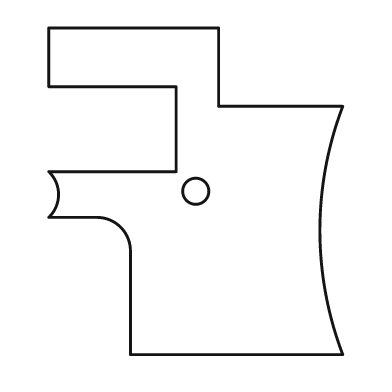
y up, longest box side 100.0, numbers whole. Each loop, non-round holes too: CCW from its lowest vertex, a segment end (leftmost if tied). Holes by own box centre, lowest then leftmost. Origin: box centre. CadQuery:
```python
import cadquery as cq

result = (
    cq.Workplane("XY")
    .moveTo(-20.0, -50.0)
    .lineTo(45.0, -50.0)
    .threePointArc((38.0, -12.0), (45.0, 26.0))
    .lineTo(7.0, 26.0)
    .lineTo(7.0, 50.0)
    .lineTo(-45.0, 50.0)
    .lineTo(-45.0, 32.0)
    .lineTo(-6.0, 32.0)
    .lineTo(-6.0, 6.0)
    .lineTo(-45.0, 6.0)
    .threePointArc((-42.0, -1.0), (-45.0, -8.0))
    .lineTo(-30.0, -8.0)
    .threePointArc((-23.0, -11.0), (-20.0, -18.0))
    .close()
    .moveTo(0.0, 0.0)
    .circle(4.0)
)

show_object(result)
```